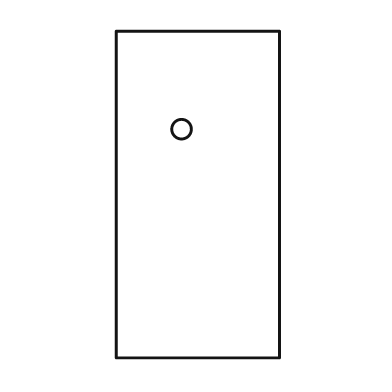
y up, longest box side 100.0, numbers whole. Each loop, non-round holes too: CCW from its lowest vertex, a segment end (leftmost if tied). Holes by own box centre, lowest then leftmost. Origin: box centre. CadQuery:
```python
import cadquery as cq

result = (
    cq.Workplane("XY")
    .moveTo(-25.0, -50.0)
    .lineTo(25.0, -50.0)
    .lineTo(25.0, 50.0)
    .lineTo(-25.0, 50.0)
    .close()
    .moveTo(-5.0, 20.0)
    .circle(3.0)
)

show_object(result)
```